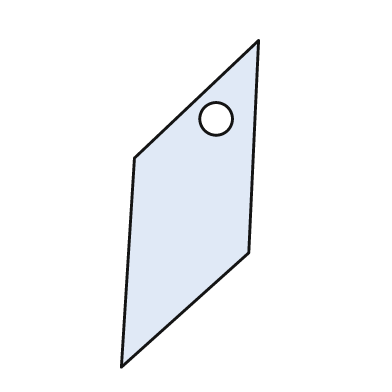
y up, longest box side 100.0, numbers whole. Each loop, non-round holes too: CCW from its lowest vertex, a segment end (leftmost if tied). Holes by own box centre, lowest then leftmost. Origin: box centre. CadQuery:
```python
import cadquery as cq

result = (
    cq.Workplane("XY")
    .moveTo(-21.0, -50.0)
    .lineTo(18.0, -15.0)
    .lineTo(21.0, 50.0)
    .lineTo(-17.0, 14.0)
    .close()
    .moveTo(8.0, 26.0)
    .circle(5.0)
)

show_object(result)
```